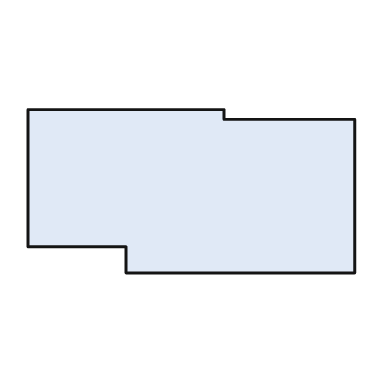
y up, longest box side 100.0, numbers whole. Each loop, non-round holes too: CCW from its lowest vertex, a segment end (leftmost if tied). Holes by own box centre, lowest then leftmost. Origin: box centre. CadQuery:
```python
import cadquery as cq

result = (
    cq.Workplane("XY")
    .moveTo(-20.0, -25.0)
    .lineTo(50.0, -25.0)
    .lineTo(50.0, 22.0)
    .lineTo(10.0, 22.0)
    .lineTo(10.0, 25.0)
    .lineTo(-50.0, 25.0)
    .lineTo(-50.0, -17.0)
    .lineTo(-20.0, -17.0)
    .close()
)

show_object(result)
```